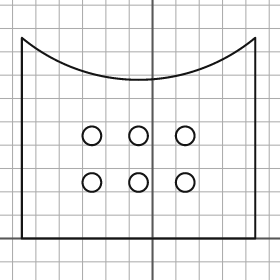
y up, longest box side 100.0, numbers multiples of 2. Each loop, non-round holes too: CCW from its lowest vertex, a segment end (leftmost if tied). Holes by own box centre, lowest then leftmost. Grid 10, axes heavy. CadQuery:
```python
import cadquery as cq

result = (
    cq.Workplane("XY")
    .moveTo(-56.0, 0.0)
    .lineTo(44.0, 0.0)
    .lineTo(44.0, 86.0)
    .threePointArc((-6.0, 68.0), (-56.0, 86.0))
    .close()
    .moveTo(-26.0, 24.0)
    .circle(4.0)
    .moveTo(-6.0, 24.0)
    .circle(4.0)
    .moveTo(14.0, 24.0)
    .circle(4.0)
    .moveTo(-26.0, 44.0)
    .circle(4.0)
    .moveTo(-6.0, 44.0)
    .circle(4.0)
    .moveTo(14.0, 44.0)
    .circle(4.0)
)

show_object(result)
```